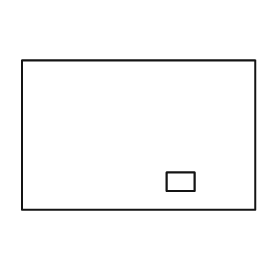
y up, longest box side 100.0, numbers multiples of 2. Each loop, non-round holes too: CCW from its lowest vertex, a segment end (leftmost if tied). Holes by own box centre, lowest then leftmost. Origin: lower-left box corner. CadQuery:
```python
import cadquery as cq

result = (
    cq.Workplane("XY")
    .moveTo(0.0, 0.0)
    .lineTo(100.0, 0.0)
    .lineTo(100.0, 64.0)
    .lineTo(0.0, 64.0)
    .close()
    .moveTo(62.0, 8.0)
    .lineTo(74.0, 8.0)
    .lineTo(74.0, 16.0)
    .lineTo(62.0, 16.0)
    .close()
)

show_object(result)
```